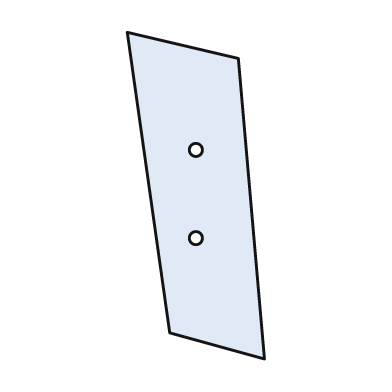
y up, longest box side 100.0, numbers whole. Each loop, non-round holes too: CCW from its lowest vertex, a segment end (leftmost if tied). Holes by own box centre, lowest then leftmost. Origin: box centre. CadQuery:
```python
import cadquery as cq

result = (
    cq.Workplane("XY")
    .moveTo(21.0, -50.0)
    .lineTo(13.0, 42.0)
    .lineTo(-21.0, 50.0)
    .lineTo(-8.0, -42.0)
    .close()
    .moveTo(0.0, -13.0)
    .circle(2.0)
    .moveTo(0.0, 14.0)
    .circle(2.0)
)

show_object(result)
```